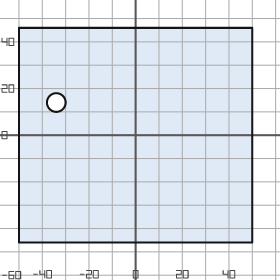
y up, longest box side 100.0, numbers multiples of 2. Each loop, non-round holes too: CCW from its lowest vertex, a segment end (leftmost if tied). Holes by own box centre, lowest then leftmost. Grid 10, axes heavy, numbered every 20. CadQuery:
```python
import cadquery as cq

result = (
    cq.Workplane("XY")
    .moveTo(-50.0, -46.0)
    .lineTo(50.0, -46.0)
    .lineTo(50.0, 46.0)
    .lineTo(-50.0, 46.0)
    .close()
    .moveTo(-34.0, 14.0)
    .circle(4.0)
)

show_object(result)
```